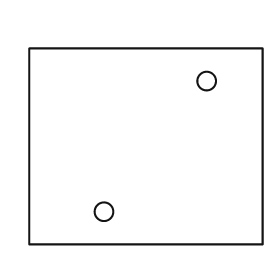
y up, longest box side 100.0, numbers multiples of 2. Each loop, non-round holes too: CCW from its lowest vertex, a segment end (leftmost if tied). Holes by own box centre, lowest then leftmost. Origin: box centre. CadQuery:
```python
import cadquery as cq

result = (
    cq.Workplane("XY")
    .moveTo(-50.0, -42.0)
    .lineTo(50.0, -42.0)
    .lineTo(50.0, 42.0)
    .lineTo(-50.0, 42.0)
    .close()
    .moveTo(-18.0, -28.0)
    .circle(4.0)
    .moveTo(26.0, 28.0)
    .circle(4.0)
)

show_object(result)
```